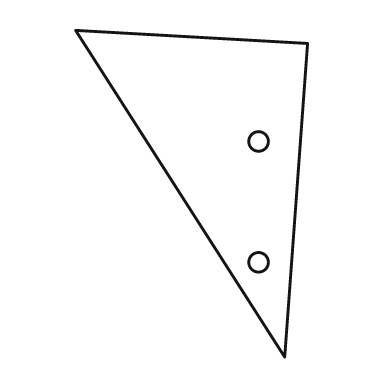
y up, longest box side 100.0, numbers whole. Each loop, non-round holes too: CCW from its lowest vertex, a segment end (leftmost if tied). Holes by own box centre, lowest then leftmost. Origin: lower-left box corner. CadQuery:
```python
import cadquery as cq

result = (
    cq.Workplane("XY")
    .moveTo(64.0, 0.0)
    .lineTo(71.0, 96.0)
    .lineTo(0.0, 100.0)
    .close()
    .moveTo(56.0, 29.0)
    .circle(3.0)
    .moveTo(56.0, 66.0)
    .circle(3.0)
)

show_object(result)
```